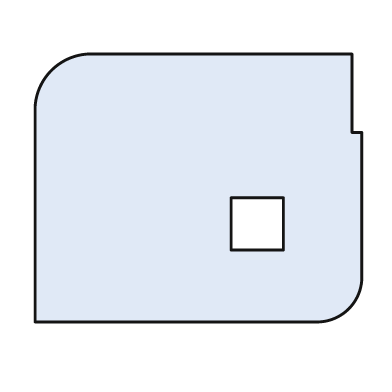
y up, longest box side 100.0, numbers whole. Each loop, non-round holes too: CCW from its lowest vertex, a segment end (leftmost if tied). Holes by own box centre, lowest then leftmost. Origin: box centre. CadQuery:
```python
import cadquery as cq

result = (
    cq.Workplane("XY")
    .moveTo(-50.0, -41.0)
    .lineTo(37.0, -41.0)
    .threePointArc((46.0, -37.0), (50.0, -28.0))
    .lineTo(50.0, 17.0)
    .lineTo(47.0, 17.0)
    .lineTo(47.0, 41.0)
    .lineTo(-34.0, 41.0)
    .threePointArc((-45.0, 36.0), (-50.0, 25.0))
    .close()
    .moveTo(10.0, -19.0)
    .lineTo(26.0, -19.0)
    .lineTo(26.0, -3.0)
    .lineTo(10.0, -3.0)
    .close()
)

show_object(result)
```